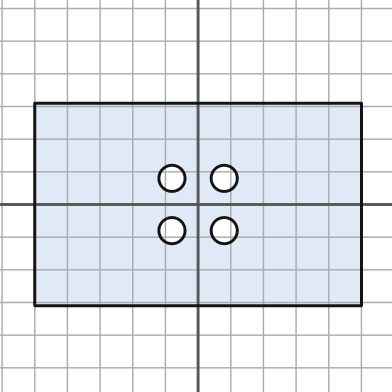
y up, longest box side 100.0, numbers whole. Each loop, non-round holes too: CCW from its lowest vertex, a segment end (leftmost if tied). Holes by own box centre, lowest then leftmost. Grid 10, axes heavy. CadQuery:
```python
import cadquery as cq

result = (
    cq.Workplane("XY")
    .moveTo(-50.0, -31.0)
    .lineTo(50.0, -31.0)
    .lineTo(50.0, 31.0)
    .lineTo(-50.0, 31.0)
    .close()
    .moveTo(-8.0, -8.0)
    .circle(4.0)
    .moveTo(8.0, -8.0)
    .circle(4.0)
    .moveTo(-8.0, 8.0)
    .circle(4.0)
    .moveTo(8.0, 8.0)
    .circle(4.0)
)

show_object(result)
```